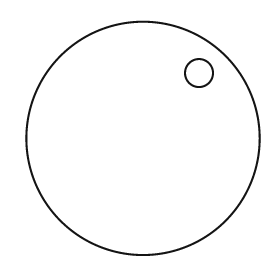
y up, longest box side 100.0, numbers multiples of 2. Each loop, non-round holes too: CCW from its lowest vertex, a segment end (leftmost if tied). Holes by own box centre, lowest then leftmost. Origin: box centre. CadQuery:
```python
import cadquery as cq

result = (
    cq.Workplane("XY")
    .moveTo(0.0, 0.0)
    .circle(50.0)
    .moveTo(24.0, 28.0)
    .circle(6.0)
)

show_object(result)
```